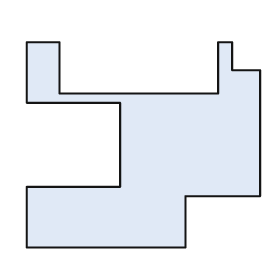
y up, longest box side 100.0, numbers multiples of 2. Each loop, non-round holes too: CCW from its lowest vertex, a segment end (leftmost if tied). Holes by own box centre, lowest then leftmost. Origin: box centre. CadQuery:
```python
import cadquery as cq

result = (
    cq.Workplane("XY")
    .moveTo(-50.0, -44.0)
    .lineTo(18.0, -44.0)
    .lineTo(18.0, -22.0)
    .lineTo(50.0, -22.0)
    .lineTo(50.0, 32.0)
    .lineTo(38.0, 32.0)
    .lineTo(38.0, 44.0)
    .lineTo(32.0, 44.0)
    .lineTo(32.0, 22.0)
    .lineTo(-36.0, 22.0)
    .lineTo(-36.0, 44.0)
    .lineTo(-50.0, 44.0)
    .lineTo(-50.0, 18.0)
    .lineTo(-10.0, 18.0)
    .lineTo(-10.0, -18.0)
    .lineTo(-50.0, -18.0)
    .close()
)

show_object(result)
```